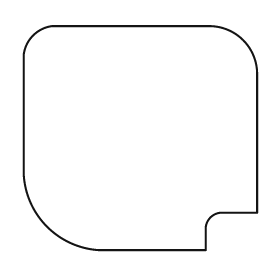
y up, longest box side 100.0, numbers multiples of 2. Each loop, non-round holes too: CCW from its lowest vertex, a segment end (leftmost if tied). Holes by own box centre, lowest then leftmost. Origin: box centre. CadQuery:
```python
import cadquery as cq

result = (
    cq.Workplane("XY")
    .moveTo(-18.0, -48.0)
    .lineTo(28.0, -48.0)
    .lineTo(28.0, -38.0)
    .threePointArc((30.0, -34.0), (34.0, -32.0))
    .lineTo(50.0, -32.0)
    .lineTo(50.0, 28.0)
    .threePointArc((44.0, 42.0), (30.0, 48.0))
    .lineTo(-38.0, 48.0)
    .threePointArc((-46.0, 44.0), (-50.0, 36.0))
    .lineTo(-50.0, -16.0)
    .threePointArc((-40.0, -38.0), (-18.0, -48.0))
    .close()
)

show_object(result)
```